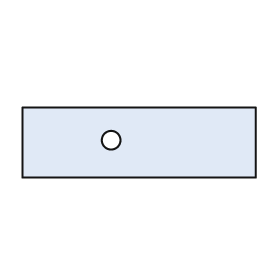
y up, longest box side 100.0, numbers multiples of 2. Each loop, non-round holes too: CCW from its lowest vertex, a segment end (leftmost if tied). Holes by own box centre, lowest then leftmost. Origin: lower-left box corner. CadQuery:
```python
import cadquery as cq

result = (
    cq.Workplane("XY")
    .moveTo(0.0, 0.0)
    .lineTo(100.0, 0.0)
    .lineTo(100.0, 30.0)
    .lineTo(0.0, 30.0)
    .close()
    .moveTo(38.0, 16.0)
    .circle(4.0)
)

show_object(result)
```